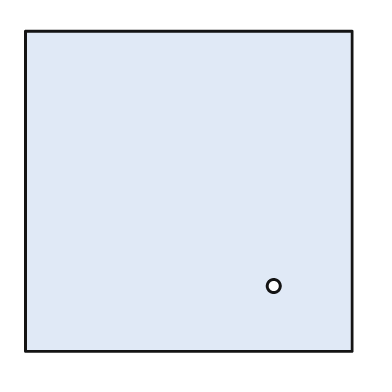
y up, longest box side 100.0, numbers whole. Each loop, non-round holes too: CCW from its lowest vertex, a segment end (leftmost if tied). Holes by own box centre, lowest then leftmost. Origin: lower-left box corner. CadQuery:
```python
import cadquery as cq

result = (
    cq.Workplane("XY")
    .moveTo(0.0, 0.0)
    .lineTo(100.0, 0.0)
    .lineTo(100.0, 98.0)
    .lineTo(0.0, 98.0)
    .close()
    .moveTo(76.0, 20.0)
    .circle(2.0)
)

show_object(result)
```